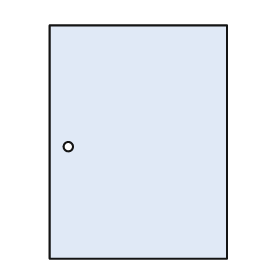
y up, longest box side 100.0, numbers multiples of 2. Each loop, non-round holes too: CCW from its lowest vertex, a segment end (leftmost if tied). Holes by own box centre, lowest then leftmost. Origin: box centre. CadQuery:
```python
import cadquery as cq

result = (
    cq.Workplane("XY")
    .moveTo(-38.0, -50.0)
    .lineTo(38.0, -50.0)
    .lineTo(38.0, 50.0)
    .lineTo(-38.0, 50.0)
    .close()
    .moveTo(-30.0, -2.0)
    .circle(2.0)
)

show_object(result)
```